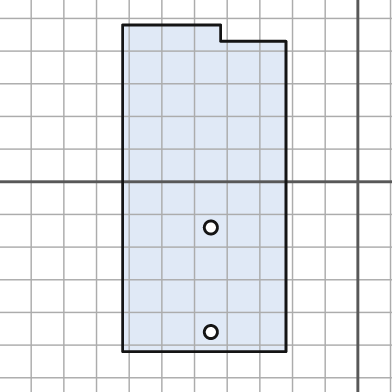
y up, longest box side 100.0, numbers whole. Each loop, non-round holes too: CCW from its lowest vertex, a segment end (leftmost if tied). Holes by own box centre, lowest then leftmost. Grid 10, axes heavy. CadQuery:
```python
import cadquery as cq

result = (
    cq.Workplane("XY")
    .moveTo(-72.0, -52.0)
    .lineTo(-22.0, -52.0)
    .lineTo(-22.0, 43.0)
    .lineTo(-42.0, 43.0)
    .lineTo(-42.0, 48.0)
    .lineTo(-72.0, 48.0)
    .close()
    .moveTo(-45.0, -46.0)
    .circle(2.0)
    .moveTo(-45.0, -14.0)
    .circle(2.0)
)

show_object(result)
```